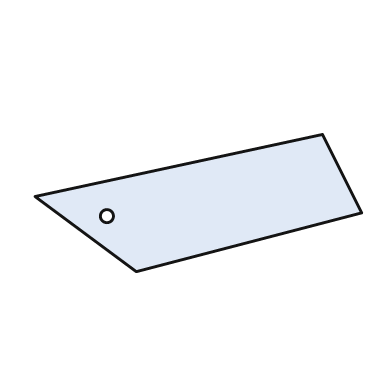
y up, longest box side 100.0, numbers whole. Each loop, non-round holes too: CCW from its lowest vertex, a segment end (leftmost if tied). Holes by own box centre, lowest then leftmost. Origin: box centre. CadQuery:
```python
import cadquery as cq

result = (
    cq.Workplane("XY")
    .moveTo(-19.0, -21.0)
    .lineTo(50.0, -3.0)
    .lineTo(38.0, 21.0)
    .lineTo(-50.0, 2.0)
    .close()
    .moveTo(-28.0, -4.0)
    .circle(2.0)
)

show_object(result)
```